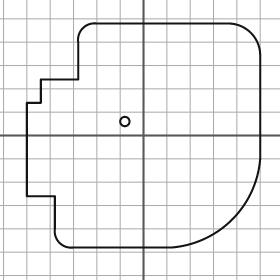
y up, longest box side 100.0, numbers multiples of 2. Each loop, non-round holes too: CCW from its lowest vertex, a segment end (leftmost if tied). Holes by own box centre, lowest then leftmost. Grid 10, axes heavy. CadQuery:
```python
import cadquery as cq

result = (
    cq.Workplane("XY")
    .moveTo(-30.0, -48.0)
    .lineTo(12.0, -48.0)
    .threePointArc((38.0, -36.0), (50.0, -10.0))
    .lineTo(50.0, 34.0)
    .threePointArc((46.0, 44.0), (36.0, 48.0))
    .lineTo(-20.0, 48.0)
    .threePointArc((-26.0, 46.0), (-28.0, 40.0))
    .lineTo(-28.0, 24.0)
    .lineTo(-44.0, 24.0)
    .lineTo(-44.0, 14.0)
    .lineTo(-50.0, 14.0)
    .lineTo(-50.0, -26.0)
    .lineTo(-38.0, -26.0)
    .lineTo(-38.0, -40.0)
    .threePointArc((-36.0, -46.0), (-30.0, -48.0))
    .close()
    .moveTo(-8.0, 6.0)
    .circle(2.0)
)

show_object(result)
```